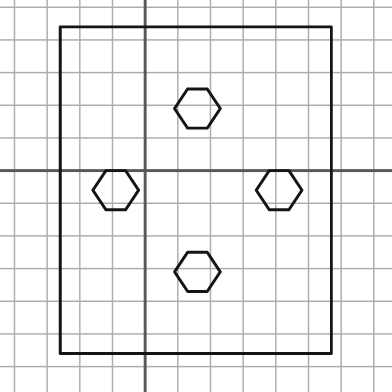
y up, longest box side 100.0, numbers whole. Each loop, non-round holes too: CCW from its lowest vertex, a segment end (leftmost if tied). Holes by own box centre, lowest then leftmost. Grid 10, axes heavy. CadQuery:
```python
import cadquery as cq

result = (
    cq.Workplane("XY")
    .moveTo(-26.0, -56.0)
    .lineTo(57.0, -56.0)
    .lineTo(57.0, 44.0)
    .lineTo(-26.0, 44.0)
    .close()
    .moveTo(13.0, -37.0)
    .lineTo(19.0, -37.0)
    .lineTo(23.0, -31.0)
    .lineTo(19.0, -25.0)
    .lineTo(13.0, -25.0)
    .lineTo(9.0, -31.0)
    .close()
    .moveTo(-12.0, -12.0)
    .lineTo(-6.0, -12.0)
    .lineTo(-2.0, -6.0)
    .lineTo(-6.0, 0.0)
    .lineTo(-12.0, 0.0)
    .lineTo(-16.0, -6.0)
    .close()
    .moveTo(38.0, -12.0)
    .lineTo(44.0, -12.0)
    .lineTo(48.0, -6.0)
    .lineTo(44.0, 0.0)
    .lineTo(38.0, 0.0)
    .lineTo(34.0, -6.0)
    .close()
    .moveTo(13.0, 13.0)
    .lineTo(19.0, 13.0)
    .lineTo(23.0, 19.0)
    .lineTo(19.0, 25.0)
    .lineTo(13.0, 25.0)
    .lineTo(9.0, 19.0)
    .close()
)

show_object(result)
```